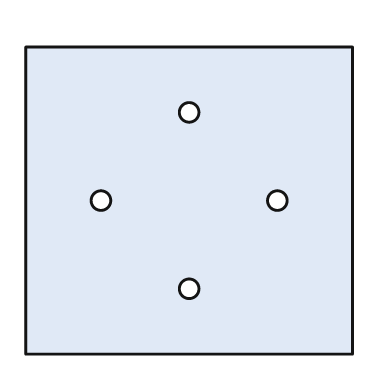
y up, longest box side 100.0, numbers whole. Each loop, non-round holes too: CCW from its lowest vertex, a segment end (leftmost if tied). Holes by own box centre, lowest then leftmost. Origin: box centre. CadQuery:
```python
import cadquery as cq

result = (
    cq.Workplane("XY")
    .moveTo(-50.0, -47.0)
    .lineTo(50.0, -47.0)
    .lineTo(50.0, 47.0)
    .lineTo(-50.0, 47.0)
    .close()
    .moveTo(0.0, -27.0)
    .circle(3.0)
    .moveTo(-27.0, 0.0)
    .circle(3.0)
    .moveTo(27.0, 0.0)
    .circle(3.0)
    .moveTo(0.0, 27.0)
    .circle(3.0)
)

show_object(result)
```